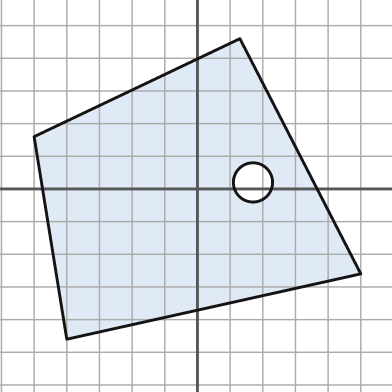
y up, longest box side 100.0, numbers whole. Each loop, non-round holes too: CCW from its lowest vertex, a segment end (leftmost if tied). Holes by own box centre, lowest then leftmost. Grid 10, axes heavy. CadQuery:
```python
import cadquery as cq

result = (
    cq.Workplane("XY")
    .moveTo(-40.0, -46.0)
    .lineTo(50.0, -26.0)
    .lineTo(13.0, 46.0)
    .lineTo(-50.0, 16.0)
    .close()
    .moveTo(17.0, 2.0)
    .circle(6.0)
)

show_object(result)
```